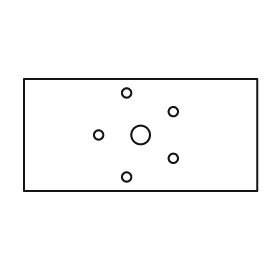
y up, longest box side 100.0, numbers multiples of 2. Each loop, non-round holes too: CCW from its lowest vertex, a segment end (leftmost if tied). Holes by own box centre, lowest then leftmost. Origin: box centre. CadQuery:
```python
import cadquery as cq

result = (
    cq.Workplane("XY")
    .moveTo(-50.0, -24.0)
    .lineTo(50.0, -24.0)
    .lineTo(50.0, 24.0)
    .lineTo(-50.0, 24.0)
    .close()
    .moveTo(-6.0, -18.0)
    .circle(2.0)
    .moveTo(14.0, -10.0)
    .circle(2.0)
    .moveTo(-18.0, 0.0)
    .circle(2.0)
    .moveTo(0.0, 0.0)
    .circle(4.0)
    .moveTo(14.0, 10.0)
    .circle(2.0)
    .moveTo(-6.0, 18.0)
    .circle(2.0)
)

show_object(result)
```